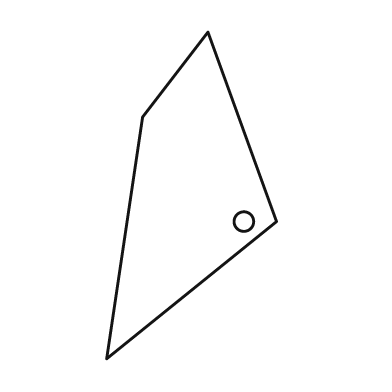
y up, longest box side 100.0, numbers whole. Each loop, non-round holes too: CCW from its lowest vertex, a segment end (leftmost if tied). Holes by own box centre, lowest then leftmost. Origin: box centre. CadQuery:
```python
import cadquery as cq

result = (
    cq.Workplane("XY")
    .moveTo(-26.0, -50.0)
    .lineTo(26.0, -8.0)
    .lineTo(5.0, 50.0)
    .lineTo(-15.0, 24.0)
    .close()
    .moveTo(16.0, -8.0)
    .circle(3.0)
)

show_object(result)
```